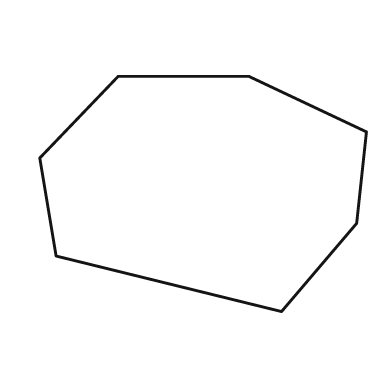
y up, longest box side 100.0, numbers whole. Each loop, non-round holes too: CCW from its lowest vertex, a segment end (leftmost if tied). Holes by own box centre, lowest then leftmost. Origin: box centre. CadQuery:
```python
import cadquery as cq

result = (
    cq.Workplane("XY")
    .moveTo(24.0, -36.0)
    .lineTo(47.0, -9.0)
    .lineTo(50.0, 19.0)
    .lineTo(14.0, 36.0)
    .lineTo(-26.0, 36.0)
    .lineTo(-50.0, 11.0)
    .lineTo(-45.0, -19.0)
    .close()
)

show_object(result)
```